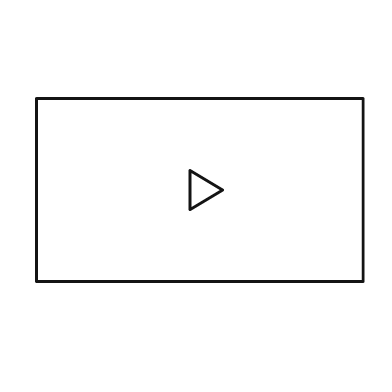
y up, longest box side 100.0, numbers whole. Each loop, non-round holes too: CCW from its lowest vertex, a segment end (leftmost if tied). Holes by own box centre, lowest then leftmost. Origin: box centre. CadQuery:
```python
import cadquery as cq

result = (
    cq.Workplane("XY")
    .moveTo(-50.0, -28.0)
    .lineTo(50.0, -28.0)
    .lineTo(50.0, 28.0)
    .lineTo(-50.0, 28.0)
    .close()
    .moveTo(-3.0, -6.0)
    .lineTo(7.0, 0.0)
    .lineTo(-3.0, 6.0)
    .close()
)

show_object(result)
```